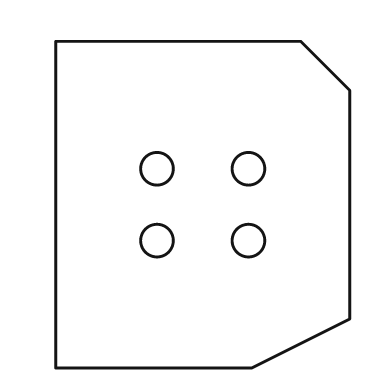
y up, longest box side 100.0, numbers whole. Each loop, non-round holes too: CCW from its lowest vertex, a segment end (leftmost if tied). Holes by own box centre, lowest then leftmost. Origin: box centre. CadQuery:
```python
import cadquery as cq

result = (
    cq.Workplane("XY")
    .moveTo(-45.0, -50.0)
    .lineTo(15.0, -50.0)
    .lineTo(45.0, -35.0)
    .lineTo(45.0, 35.0)
    .lineTo(30.0, 50.0)
    .lineTo(-45.0, 50.0)
    .close()
    .moveTo(-14.0, -11.0)
    .circle(5.0)
    .moveTo(14.0, -11.0)
    .circle(5.0)
    .moveTo(-14.0, 11.0)
    .circle(5.0)
    .moveTo(14.0, 11.0)
    .circle(5.0)
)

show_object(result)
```